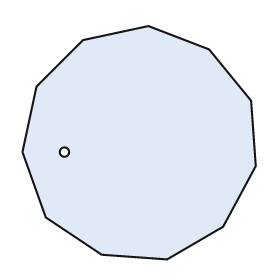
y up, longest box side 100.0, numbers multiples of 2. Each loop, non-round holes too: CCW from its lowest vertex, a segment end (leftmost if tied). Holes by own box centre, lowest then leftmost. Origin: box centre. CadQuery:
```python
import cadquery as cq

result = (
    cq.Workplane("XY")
    .moveTo(12.0, -50.0)
    .lineTo(36.0, -36.0)
    .lineTo(50.0, -10.0)
    .lineTo(48.0, 18.0)
    .lineTo(30.0, 40.0)
    .lineTo(4.0, 50.0)
    .lineTo(-24.0, 44.0)
    .lineTo(-44.0, 24.0)
    .lineTo(-50.0, -4.0)
    .lineTo(-40.0, -32.0)
    .lineTo(-16.0, -48.0)
    .close()
    .moveTo(-32.0, -4.0)
    .circle(2.0)
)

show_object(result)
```